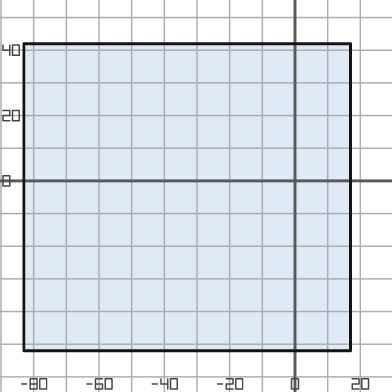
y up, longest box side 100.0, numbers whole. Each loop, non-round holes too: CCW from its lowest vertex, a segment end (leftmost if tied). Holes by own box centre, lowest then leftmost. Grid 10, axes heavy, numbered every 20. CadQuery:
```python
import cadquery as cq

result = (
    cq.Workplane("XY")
    .moveTo(-83.0, -52.0)
    .lineTo(17.0, -52.0)
    .lineTo(17.0, 42.0)
    .lineTo(-83.0, 42.0)
    .close()
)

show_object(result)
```